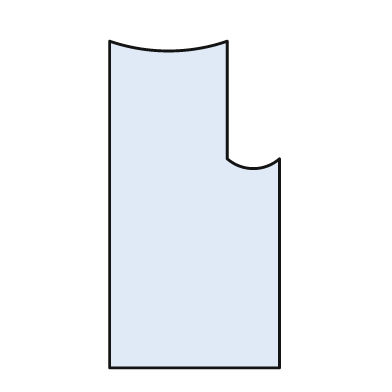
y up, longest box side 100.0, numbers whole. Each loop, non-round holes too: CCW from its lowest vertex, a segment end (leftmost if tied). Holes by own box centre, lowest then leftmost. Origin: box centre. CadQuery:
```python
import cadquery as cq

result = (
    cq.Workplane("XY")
    .moveTo(-26.0, -50.0)
    .lineTo(26.0, -50.0)
    .lineTo(26.0, 14.0)
    .threePointArc((18.0, 11.0), (10.0, 14.0))
    .lineTo(10.0, 50.0)
    .threePointArc((-8.0, 47.0), (-26.0, 50.0))
    .close()
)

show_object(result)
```